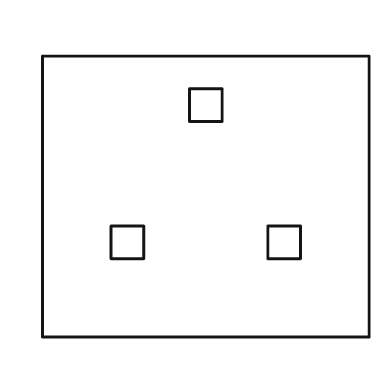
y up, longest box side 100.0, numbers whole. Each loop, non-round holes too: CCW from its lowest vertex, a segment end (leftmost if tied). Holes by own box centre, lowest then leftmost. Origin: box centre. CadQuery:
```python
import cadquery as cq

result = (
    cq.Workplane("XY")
    .moveTo(-50.0, -43.0)
    .lineTo(50.0, -43.0)
    .lineTo(50.0, 43.0)
    .lineTo(-50.0, 43.0)
    .close()
    .moveTo(-29.0, -19.0)
    .lineTo(-19.0, -19.0)
    .lineTo(-19.0, -9.0)
    .lineTo(-29.0, -9.0)
    .close()
    .moveTo(19.0, -19.0)
    .lineTo(29.0, -19.0)
    .lineTo(29.0, -9.0)
    .lineTo(19.0, -9.0)
    .close()
    .moveTo(-5.0, 23.0)
    .lineTo(5.0, 23.0)
    .lineTo(5.0, 33.0)
    .lineTo(-5.0, 33.0)
    .close()
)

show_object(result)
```